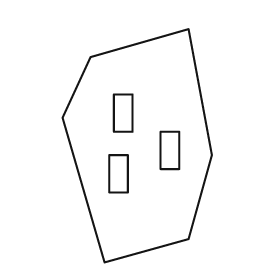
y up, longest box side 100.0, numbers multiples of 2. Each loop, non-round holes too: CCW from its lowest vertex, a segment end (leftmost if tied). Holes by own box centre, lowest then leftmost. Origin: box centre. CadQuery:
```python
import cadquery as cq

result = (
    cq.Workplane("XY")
    .moveTo(-14.0, -50.0)
    .lineTo(22.0, -40.0)
    .lineTo(32.0, -4.0)
    .lineTo(22.0, 50.0)
    .lineTo(-20.0, 38.0)
    .lineTo(-32.0, 12.0)
    .close()
    .moveTo(-12.0, -20.0)
    .lineTo(-4.0, -20.0)
    .lineTo(-4.0, -4.0)
    .lineTo(-12.0, -4.0)
    .close()
    .moveTo(10.0, -10.0)
    .lineTo(18.0, -10.0)
    .lineTo(18.0, 6.0)
    .lineTo(10.0, 6.0)
    .close()
    .moveTo(-10.0, 6.0)
    .lineTo(-2.0, 6.0)
    .lineTo(-2.0, 22.0)
    .lineTo(-10.0, 22.0)
    .close()
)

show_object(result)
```